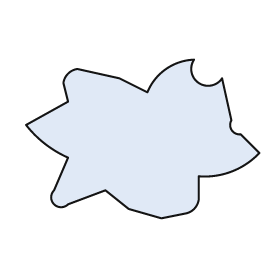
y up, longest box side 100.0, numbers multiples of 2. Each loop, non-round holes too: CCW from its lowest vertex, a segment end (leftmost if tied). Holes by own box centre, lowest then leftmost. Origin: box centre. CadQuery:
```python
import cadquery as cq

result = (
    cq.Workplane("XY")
    .moveTo(8.0, -34.0)
    .lineTo(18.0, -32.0)
    .threePointArc((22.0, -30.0), (24.0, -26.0))
    .lineTo(24.0, -16.0)
    .threePointArc((38.0, -14.0), (50.0, -6.0))
    .lineTo(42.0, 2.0)
    .threePointArc((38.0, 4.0), (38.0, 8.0))
    .lineTo(34.0, 26.0)
    .threePointArc((24.0, 24.0), (22.0, 34.0))
    .threePointArc((10.0, 30.0), (2.0, 20.0))
    .lineTo(-10.0, 26.0)
    .lineTo(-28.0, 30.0)
    .threePointArc((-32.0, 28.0), (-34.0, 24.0))
    .lineTo(-32.0, 16.0)
    .lineTo(-50.0, 6.0)
    .threePointArc((-42.0, -2.0), (-32.0, -8.0))
    .lineTo(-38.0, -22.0)
    .threePointArc((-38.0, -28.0), (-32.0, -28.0))
    .lineTo(-16.0, -22.0)
    .lineTo(-6.0, -30.0)
    .close()
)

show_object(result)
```